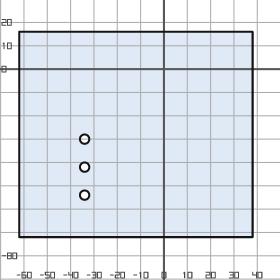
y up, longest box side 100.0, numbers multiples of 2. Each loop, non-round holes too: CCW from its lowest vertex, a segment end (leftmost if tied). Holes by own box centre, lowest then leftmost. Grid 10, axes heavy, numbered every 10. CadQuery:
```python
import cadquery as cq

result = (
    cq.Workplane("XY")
    .moveTo(-62.0, -72.0)
    .lineTo(38.0, -72.0)
    .lineTo(38.0, 16.0)
    .lineTo(-62.0, 16.0)
    .close()
    .moveTo(-34.0, -54.0)
    .circle(2.0)
    .moveTo(-34.0, -42.0)
    .circle(2.0)
    .moveTo(-34.0, -30.0)
    .circle(2.0)
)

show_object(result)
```